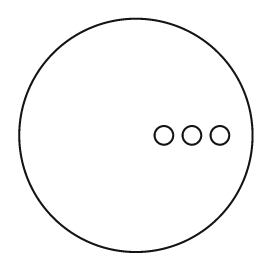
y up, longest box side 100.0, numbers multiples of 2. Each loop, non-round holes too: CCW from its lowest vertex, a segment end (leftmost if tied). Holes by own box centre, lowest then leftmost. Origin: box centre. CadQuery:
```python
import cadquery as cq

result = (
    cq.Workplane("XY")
    .moveTo(0.0, 0.0)
    .circle(50.0)
    .moveTo(12.0, 0.0)
    .circle(4.0)
    .moveTo(24.0, 0.0)
    .circle(4.0)
    .moveTo(36.0, 0.0)
    .circle(4.0)
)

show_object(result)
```